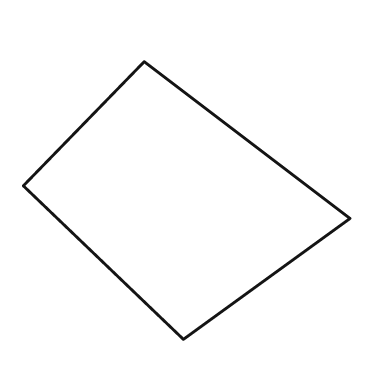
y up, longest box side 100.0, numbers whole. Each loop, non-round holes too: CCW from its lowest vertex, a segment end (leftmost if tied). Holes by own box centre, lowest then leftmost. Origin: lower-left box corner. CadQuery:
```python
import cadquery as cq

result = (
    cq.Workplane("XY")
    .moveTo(49.0, 0.0)
    .lineTo(100.0, 37.0)
    .lineTo(37.0, 85.0)
    .lineTo(0.0, 47.0)
    .close()
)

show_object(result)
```